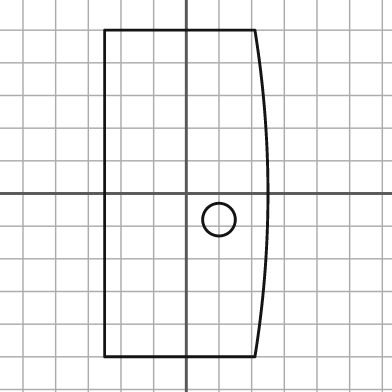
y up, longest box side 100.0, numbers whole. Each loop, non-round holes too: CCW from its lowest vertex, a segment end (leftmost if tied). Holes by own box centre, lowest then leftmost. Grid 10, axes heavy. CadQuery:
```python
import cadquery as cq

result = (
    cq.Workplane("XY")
    .moveTo(-25.0, -50.0)
    .lineTo(21.0, -50.0)
    .threePointArc((25.0, 0.0), (21.0, 50.0))
    .lineTo(-25.0, 50.0)
    .close()
    .moveTo(10.0, -8.0)
    .circle(5.0)
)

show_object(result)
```